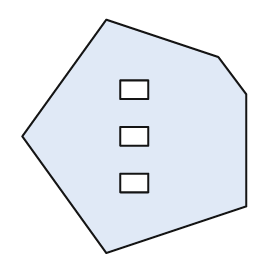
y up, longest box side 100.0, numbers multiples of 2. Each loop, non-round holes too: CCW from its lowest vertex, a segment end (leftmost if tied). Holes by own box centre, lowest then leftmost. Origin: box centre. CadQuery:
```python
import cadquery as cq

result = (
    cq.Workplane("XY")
    .moveTo(-12.0, -50.0)
    .lineTo(48.0, -30.0)
    .lineTo(48.0, 18.0)
    .lineTo(36.0, 34.0)
    .lineTo(-12.0, 50.0)
    .lineTo(-48.0, 0.0)
    .close()
    .moveTo(-6.0, -24.0)
    .lineTo(6.0, -24.0)
    .lineTo(6.0, -16.0)
    .lineTo(-6.0, -16.0)
    .close()
    .moveTo(-6.0, -4.0)
    .lineTo(6.0, -4.0)
    .lineTo(6.0, 4.0)
    .lineTo(-6.0, 4.0)
    .close()
    .moveTo(-6.0, 16.0)
    .lineTo(6.0, 16.0)
    .lineTo(6.0, 24.0)
    .lineTo(-6.0, 24.0)
    .close()
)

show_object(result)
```